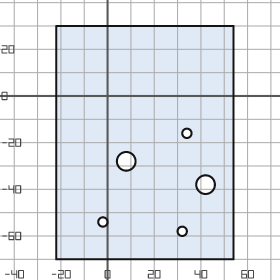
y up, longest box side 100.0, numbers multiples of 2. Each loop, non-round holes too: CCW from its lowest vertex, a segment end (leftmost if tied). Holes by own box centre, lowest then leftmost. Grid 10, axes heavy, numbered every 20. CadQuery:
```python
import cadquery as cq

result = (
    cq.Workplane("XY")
    .moveTo(-22.0, -70.0)
    .lineTo(54.0, -70.0)
    .lineTo(54.0, 30.0)
    .lineTo(-22.0, 30.0)
    .close()
    .moveTo(32.0, -58.0)
    .circle(2.0)
    .moveTo(-2.0, -54.0)
    .circle(2.0)
    .moveTo(42.0, -38.0)
    .circle(4.0)
    .moveTo(8.0, -28.0)
    .circle(4.0)
    .moveTo(34.0, -16.0)
    .circle(2.0)
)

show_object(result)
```